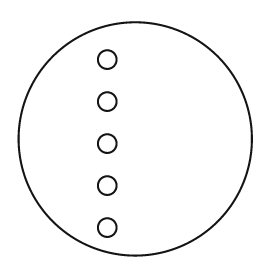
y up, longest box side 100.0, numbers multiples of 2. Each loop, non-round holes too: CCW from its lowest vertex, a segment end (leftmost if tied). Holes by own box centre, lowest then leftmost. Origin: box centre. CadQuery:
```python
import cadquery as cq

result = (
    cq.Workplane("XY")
    .moveTo(0.0, 0.0)
    .circle(50.0)
    .moveTo(-12.0, -38.0)
    .circle(4.0)
    .moveTo(-12.0, -20.0)
    .circle(4.0)
    .moveTo(-12.0, -2.0)
    .circle(4.0)
    .moveTo(-12.0, 16.0)
    .circle(4.0)
    .moveTo(-12.0, 34.0)
    .circle(4.0)
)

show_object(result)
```